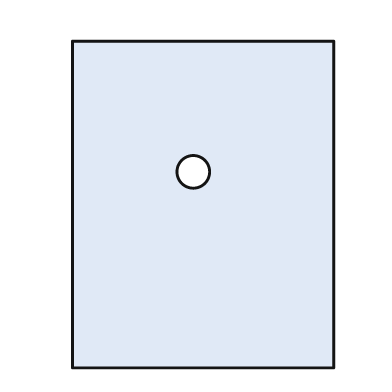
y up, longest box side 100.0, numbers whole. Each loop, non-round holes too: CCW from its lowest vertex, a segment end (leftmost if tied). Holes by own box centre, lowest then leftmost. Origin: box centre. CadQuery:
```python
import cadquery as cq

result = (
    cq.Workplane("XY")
    .moveTo(-40.0, -50.0)
    .lineTo(40.0, -50.0)
    .lineTo(40.0, 50.0)
    .lineTo(-40.0, 50.0)
    .close()
    .moveTo(-3.0, 10.0)
    .circle(5.0)
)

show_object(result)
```